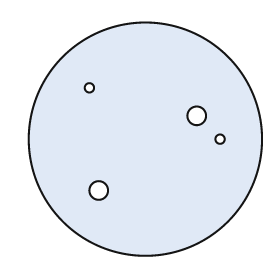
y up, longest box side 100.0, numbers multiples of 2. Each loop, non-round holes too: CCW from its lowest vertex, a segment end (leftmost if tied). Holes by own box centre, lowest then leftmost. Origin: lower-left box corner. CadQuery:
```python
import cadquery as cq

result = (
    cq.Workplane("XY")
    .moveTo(50.0, 50.0)
    .circle(50.0)
    .moveTo(30.0, 28.0)
    .circle(4.0)
    .moveTo(82.0, 50.0)
    .circle(2.0)
    .moveTo(72.0, 60.0)
    .circle(4.0)
    .moveTo(26.0, 72.0)
    .circle(2.0)
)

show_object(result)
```